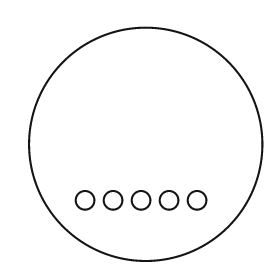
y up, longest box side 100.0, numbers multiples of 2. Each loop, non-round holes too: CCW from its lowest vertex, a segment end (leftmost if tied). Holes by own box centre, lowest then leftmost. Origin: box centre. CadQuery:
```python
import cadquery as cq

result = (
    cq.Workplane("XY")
    .moveTo(0.0, 0.0)
    .circle(50.0)
    .moveTo(-26.0, -24.0)
    .circle(4.0)
    .moveTo(-14.0, -24.0)
    .circle(4.0)
    .moveTo(-2.0, -24.0)
    .circle(4.0)
    .moveTo(10.0, -24.0)
    .circle(4.0)
    .moveTo(22.0, -24.0)
    .circle(4.0)
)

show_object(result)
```